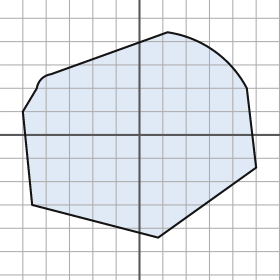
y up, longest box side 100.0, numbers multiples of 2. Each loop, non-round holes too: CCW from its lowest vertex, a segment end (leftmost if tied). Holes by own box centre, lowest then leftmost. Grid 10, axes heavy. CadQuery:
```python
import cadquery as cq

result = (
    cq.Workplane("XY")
    .moveTo(8.0, -44.0)
    .lineTo(50.0, -14.0)
    .lineTo(46.0, 20.0)
    .threePointArc((32.0, 36.0), (12.0, 44.0))
    .lineTo(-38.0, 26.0)
    .threePointArc((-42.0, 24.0), (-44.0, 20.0))
    .lineTo(-50.0, 10.0)
    .lineTo(-46.0, -30.0)
    .close()
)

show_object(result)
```